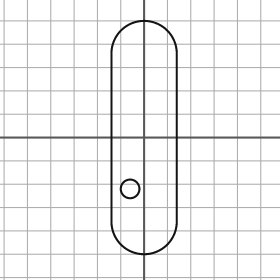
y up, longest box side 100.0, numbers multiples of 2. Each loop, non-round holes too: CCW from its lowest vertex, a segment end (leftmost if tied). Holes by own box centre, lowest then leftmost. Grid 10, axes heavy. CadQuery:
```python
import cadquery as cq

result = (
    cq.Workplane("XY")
    .moveTo(-14.0, -36.0)
    .threePointArc((0.0, -50.0), (14.0, -36.0))
    .lineTo(14.0, 36.0)
    .threePointArc((0.0, 50.0), (-14.0, 36.0))
    .close()
    .moveTo(-6.0, -22.0)
    .circle(4.0)
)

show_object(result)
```